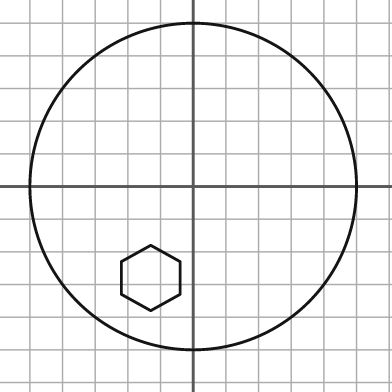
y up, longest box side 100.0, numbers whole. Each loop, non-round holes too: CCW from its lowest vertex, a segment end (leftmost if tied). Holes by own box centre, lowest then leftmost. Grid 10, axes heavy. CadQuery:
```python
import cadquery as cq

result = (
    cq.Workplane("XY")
    .moveTo(0.0, 0.0)
    .circle(50.0)
    .moveTo(-13.0, -38.0)
    .lineTo(-4.0, -33.0)
    .lineTo(-4.0, -23.0)
    .lineTo(-13.0, -18.0)
    .lineTo(-22.0, -23.0)
    .lineTo(-22.0, -33.0)
    .close()
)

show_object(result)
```